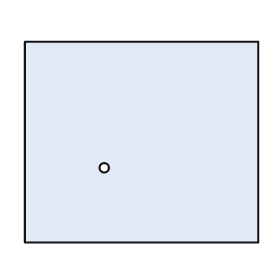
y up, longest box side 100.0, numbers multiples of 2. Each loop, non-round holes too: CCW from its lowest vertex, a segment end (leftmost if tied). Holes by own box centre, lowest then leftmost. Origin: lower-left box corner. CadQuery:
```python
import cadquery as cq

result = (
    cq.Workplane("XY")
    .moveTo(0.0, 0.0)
    .lineTo(100.0, 0.0)
    .lineTo(100.0, 86.0)
    .lineTo(0.0, 86.0)
    .close()
    .moveTo(34.0, 32.0)
    .circle(2.0)
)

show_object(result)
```